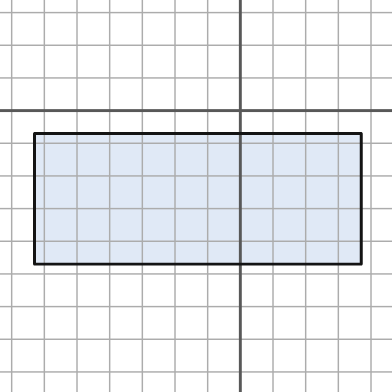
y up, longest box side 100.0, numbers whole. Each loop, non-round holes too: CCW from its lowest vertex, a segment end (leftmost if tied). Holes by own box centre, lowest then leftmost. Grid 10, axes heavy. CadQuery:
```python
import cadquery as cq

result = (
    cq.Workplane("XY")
    .moveTo(-63.0, -47.0)
    .lineTo(37.0, -47.0)
    .lineTo(37.0, -7.0)
    .lineTo(-63.0, -7.0)
    .close()
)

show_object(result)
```